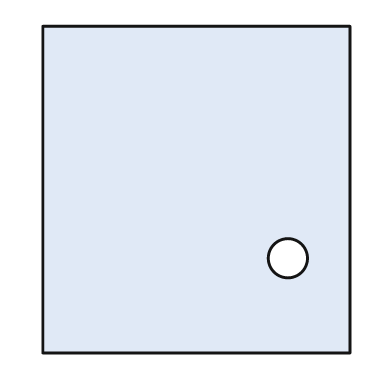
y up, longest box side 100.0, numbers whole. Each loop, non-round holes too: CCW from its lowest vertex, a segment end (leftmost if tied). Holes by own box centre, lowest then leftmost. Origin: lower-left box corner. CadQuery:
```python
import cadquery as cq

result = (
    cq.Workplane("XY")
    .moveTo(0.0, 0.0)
    .lineTo(94.0, 0.0)
    .lineTo(94.0, 100.0)
    .lineTo(0.0, 100.0)
    .close()
    .moveTo(75.0, 29.0)
    .circle(6.0)
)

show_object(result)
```